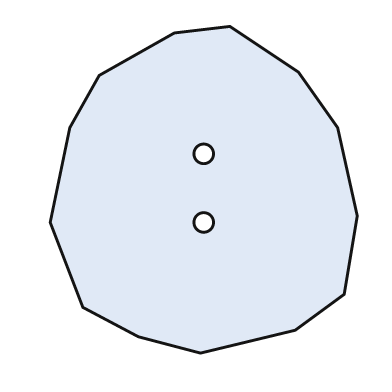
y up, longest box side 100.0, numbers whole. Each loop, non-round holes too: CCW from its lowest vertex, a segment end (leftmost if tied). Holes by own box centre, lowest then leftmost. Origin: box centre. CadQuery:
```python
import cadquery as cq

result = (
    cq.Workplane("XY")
    .moveTo(-1.0, -50.0)
    .lineTo(28.0, -43.0)
    .lineTo(43.0, -32.0)
    .lineTo(47.0, -8.0)
    .lineTo(41.0, 19.0)
    .lineTo(29.0, 36.0)
    .lineTo(8.0, 50.0)
    .lineTo(-9.0, 48.0)
    .lineTo(-32.0, 35.0)
    .lineTo(-41.0, 19.0)
    .lineTo(-47.0, -10.0)
    .lineTo(-37.0, -36.0)
    .lineTo(-20.0, -45.0)
    .close()
    .moveTo(0.0, -10.0)
    .circle(3.0)
    .moveTo(0.0, 11.0)
    .circle(3.0)
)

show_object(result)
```